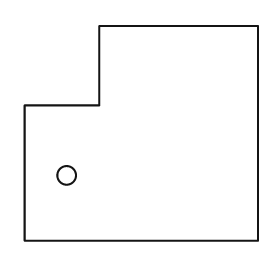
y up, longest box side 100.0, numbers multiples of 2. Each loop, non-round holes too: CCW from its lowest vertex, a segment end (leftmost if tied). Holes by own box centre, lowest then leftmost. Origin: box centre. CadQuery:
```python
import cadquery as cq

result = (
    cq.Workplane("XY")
    .moveTo(-50.0, -46.0)
    .lineTo(50.0, -46.0)
    .lineTo(50.0, 46.0)
    .lineTo(-18.0, 46.0)
    .lineTo(-18.0, 12.0)
    .lineTo(-50.0, 12.0)
    .close()
    .moveTo(-32.0, -18.0)
    .circle(4.0)
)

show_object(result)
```